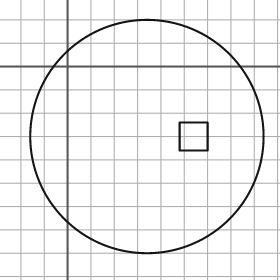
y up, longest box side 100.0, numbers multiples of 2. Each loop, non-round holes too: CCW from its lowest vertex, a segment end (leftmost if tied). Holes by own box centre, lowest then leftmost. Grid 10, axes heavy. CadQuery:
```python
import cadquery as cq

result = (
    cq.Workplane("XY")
    .moveTo(34.0, -30.0)
    .circle(50.0)
    .moveTo(48.0, -36.0)
    .lineTo(60.0, -36.0)
    .lineTo(60.0, -24.0)
    .lineTo(48.0, -24.0)
    .close()
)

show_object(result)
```